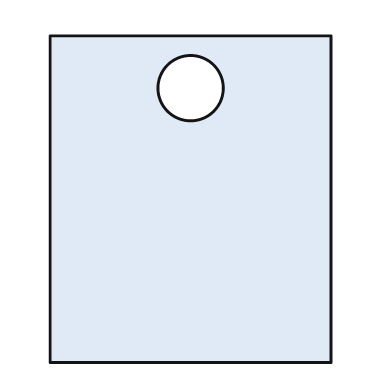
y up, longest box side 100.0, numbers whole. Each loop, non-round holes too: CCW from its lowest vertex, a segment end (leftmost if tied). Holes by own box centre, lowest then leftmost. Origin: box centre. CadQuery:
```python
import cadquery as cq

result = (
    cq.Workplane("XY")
    .moveTo(-43.0, -50.0)
    .lineTo(43.0, -50.0)
    .lineTo(43.0, 50.0)
    .lineTo(-43.0, 50.0)
    .close()
    .moveTo(0.0, 34.0)
    .circle(10.0)
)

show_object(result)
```